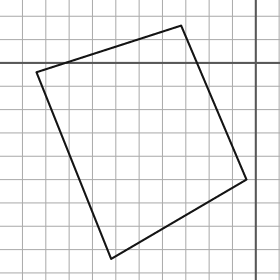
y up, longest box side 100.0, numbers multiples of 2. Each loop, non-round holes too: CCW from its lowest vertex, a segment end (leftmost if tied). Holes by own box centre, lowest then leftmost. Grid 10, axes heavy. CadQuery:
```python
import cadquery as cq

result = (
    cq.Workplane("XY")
    .moveTo(-62.0, -84.0)
    .lineTo(-4.0, -50.0)
    .lineTo(-32.0, 16.0)
    .lineTo(-94.0, -4.0)
    .close()
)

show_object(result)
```